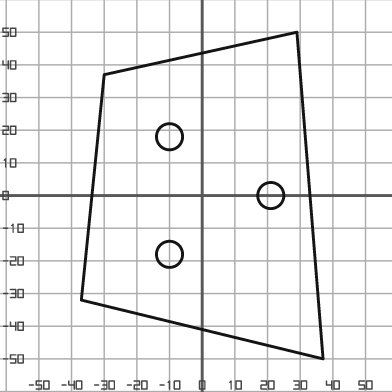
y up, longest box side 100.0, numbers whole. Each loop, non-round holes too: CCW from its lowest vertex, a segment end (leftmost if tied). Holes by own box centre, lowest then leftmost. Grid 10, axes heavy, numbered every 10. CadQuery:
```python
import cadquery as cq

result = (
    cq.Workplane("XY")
    .moveTo(37.0, -50.0)
    .lineTo(29.0, 50.0)
    .lineTo(-30.0, 37.0)
    .lineTo(-37.0, -32.0)
    .close()
    .moveTo(-10.0, -18.0)
    .circle(4.0)
    .moveTo(21.0, 0.0)
    .circle(4.0)
    .moveTo(-10.0, 18.0)
    .circle(4.0)
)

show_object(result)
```